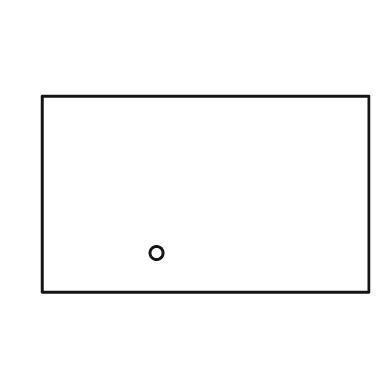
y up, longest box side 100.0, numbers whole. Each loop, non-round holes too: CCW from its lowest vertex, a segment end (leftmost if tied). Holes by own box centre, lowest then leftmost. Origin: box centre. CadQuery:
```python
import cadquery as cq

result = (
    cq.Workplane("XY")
    .moveTo(-50.0, -30.0)
    .lineTo(50.0, -30.0)
    .lineTo(50.0, 30.0)
    .lineTo(-50.0, 30.0)
    .close()
    .moveTo(-15.0, -18.0)
    .circle(2.0)
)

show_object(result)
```